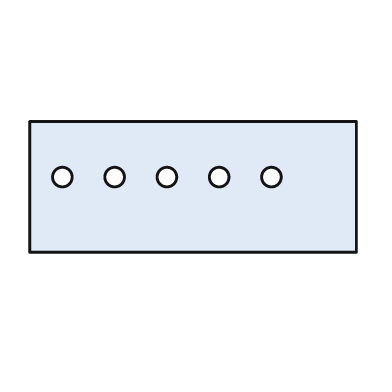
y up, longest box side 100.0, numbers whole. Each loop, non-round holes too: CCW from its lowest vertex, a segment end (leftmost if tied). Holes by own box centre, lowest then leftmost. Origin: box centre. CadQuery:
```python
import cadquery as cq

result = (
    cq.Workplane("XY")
    .moveTo(-50.0, -20.0)
    .lineTo(50.0, -20.0)
    .lineTo(50.0, 20.0)
    .lineTo(-50.0, 20.0)
    .close()
    .moveTo(-40.0, 3.0)
    .circle(3.0)
    .moveTo(-24.0, 3.0)
    .circle(3.0)
    .moveTo(-8.0, 3.0)
    .circle(3.0)
    .moveTo(8.0, 3.0)
    .circle(3.0)
    .moveTo(24.0, 3.0)
    .circle(3.0)
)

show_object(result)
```